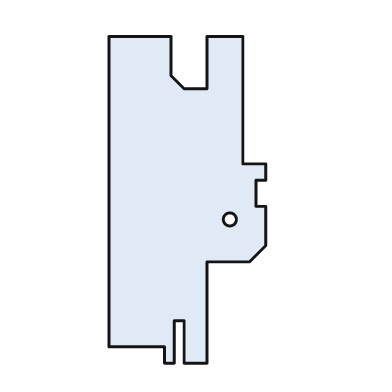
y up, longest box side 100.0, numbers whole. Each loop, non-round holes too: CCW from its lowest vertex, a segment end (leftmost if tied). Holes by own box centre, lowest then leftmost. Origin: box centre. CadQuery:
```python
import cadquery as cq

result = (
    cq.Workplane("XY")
    .moveTo(-7.0, -50.0)
    .lineTo(-4.0, -50.0)
    .lineTo(-4.0, -37.0)
    .lineTo(-1.0, -37.0)
    .lineTo(-1.0, -50.0)
    .lineTo(6.0, -50.0)
    .lineTo(6.0, -19.0)
    .lineTo(19.0, -19.0)
    .lineTo(24.0, -14.0)
    .lineTo(24.0, -2.0)
    .lineTo(21.0, -2.0)
    .lineTo(21.0, 6.0)
    .lineTo(24.0, 6.0)
    .lineTo(24.0, 11.0)
    .lineTo(17.0, 11.0)
    .lineTo(17.0, 50.0)
    .lineTo(6.0, 50.0)
    .lineTo(6.0, 34.0)
    .lineTo(-1.0, 34.0)
    .lineTo(-5.0, 38.0)
    .lineTo(-5.0, 50.0)
    .lineTo(-24.0, 50.0)
    .lineTo(-24.0, -45.0)
    .lineTo(-7.0, -45.0)
    .close()
    .moveTo(13.0, -6.0)
    .circle(2.0)
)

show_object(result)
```